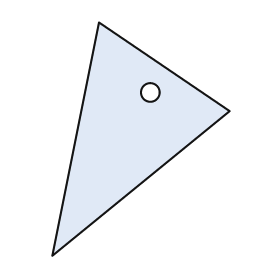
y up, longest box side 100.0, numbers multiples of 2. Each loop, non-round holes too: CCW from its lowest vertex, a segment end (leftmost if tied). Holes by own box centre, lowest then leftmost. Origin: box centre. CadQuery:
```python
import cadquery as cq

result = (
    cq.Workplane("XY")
    .moveTo(-38.0, -50.0)
    .lineTo(38.0, 12.0)
    .lineTo(-18.0, 50.0)
    .close()
    .moveTo(4.0, 20.0)
    .circle(4.0)
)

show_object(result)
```